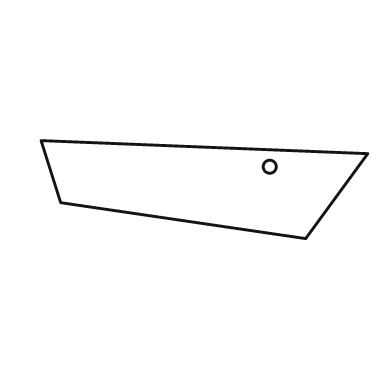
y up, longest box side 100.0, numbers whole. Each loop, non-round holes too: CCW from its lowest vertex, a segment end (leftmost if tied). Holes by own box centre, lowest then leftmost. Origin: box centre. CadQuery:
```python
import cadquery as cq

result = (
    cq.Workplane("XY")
    .moveTo(31.0, -15.0)
    .lineTo(50.0, 11.0)
    .lineTo(-50.0, 15.0)
    .lineTo(-44.0, -4.0)
    .close()
    .moveTo(20.0, 7.0)
    .circle(2.0)
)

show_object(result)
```